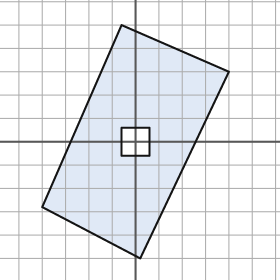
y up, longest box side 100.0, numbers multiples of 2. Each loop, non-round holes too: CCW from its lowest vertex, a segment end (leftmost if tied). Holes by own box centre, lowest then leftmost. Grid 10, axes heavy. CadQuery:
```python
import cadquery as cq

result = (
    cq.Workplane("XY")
    .moveTo(2.0, -50.0)
    .lineTo(40.0, 30.0)
    .lineTo(-6.0, 50.0)
    .lineTo(-40.0, -28.0)
    .close()
    .moveTo(-6.0, -6.0)
    .lineTo(6.0, -6.0)
    .lineTo(6.0, 6.0)
    .lineTo(-6.0, 6.0)
    .close()
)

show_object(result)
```